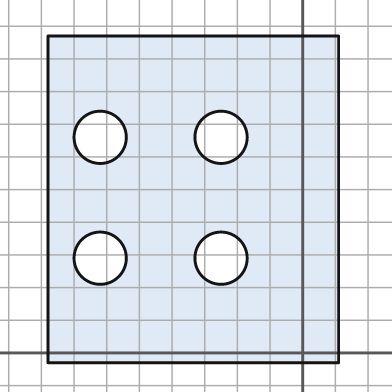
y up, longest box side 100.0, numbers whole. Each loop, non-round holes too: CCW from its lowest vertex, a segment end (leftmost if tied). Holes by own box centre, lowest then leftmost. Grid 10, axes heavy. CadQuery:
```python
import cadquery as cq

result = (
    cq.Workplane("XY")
    .moveTo(-78.0, -3.0)
    .lineTo(11.0, -3.0)
    .lineTo(11.0, 97.0)
    .lineTo(-78.0, 97.0)
    .close()
    .moveTo(-62.0, 29.0)
    .circle(8.0)
    .moveTo(-25.0, 29.0)
    .circle(8.0)
    .moveTo(-62.0, 66.0)
    .circle(8.0)
    .moveTo(-25.0, 66.0)
    .circle(8.0)
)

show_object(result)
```